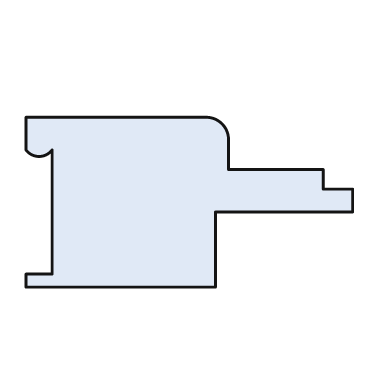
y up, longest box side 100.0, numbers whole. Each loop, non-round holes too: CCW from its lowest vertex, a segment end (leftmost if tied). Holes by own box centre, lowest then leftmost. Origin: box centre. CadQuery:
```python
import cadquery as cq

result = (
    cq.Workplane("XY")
    .moveTo(-50.0, -26.0)
    .lineTo(8.0, -26.0)
    .lineTo(8.0, -3.0)
    .lineTo(50.0, -3.0)
    .lineTo(50.0, 4.0)
    .lineTo(41.0, 4.0)
    .lineTo(41.0, 10.0)
    .lineTo(12.0, 10.0)
    .lineTo(12.0, 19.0)
    .threePointArc((10.0, 24.0), (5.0, 26.0))
    .lineTo(-50.0, 26.0)
    .lineTo(-50.0, 16.0)
    .threePointArc((-46.0, 14.0), (-42.0, 16.0))
    .lineTo(-42.0, -22.0)
    .lineTo(-50.0, -22.0)
    .close()
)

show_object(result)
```